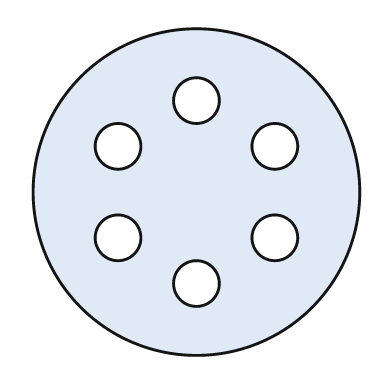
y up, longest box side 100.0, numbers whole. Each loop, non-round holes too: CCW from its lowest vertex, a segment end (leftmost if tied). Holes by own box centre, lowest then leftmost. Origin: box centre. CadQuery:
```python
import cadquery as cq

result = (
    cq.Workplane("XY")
    .moveTo(0.0, 0.0)
    .circle(50.0)
    .moveTo(0.0, -28.0)
    .circle(7.0)
    .moveTo(-24.0, -14.0)
    .circle(7.0)
    .moveTo(24.0, -14.0)
    .circle(7.0)
    .moveTo(-24.0, 14.0)
    .circle(7.0)
    .moveTo(24.0, 14.0)
    .circle(7.0)
    .moveTo(0.0, 28.0)
    .circle(7.0)
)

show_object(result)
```